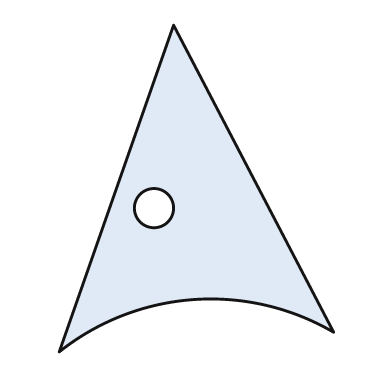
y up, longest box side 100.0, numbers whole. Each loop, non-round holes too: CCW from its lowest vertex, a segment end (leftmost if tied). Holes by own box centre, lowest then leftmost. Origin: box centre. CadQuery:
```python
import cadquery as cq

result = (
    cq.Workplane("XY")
    .moveTo(-42.0, -50.0)
    .threePointArc((-1.0, -34.0), (42.0, -44.0))
    .lineTo(-7.0, 50.0)
    .close()
    .moveTo(-13.0, -6.0)
    .circle(6.0)
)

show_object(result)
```